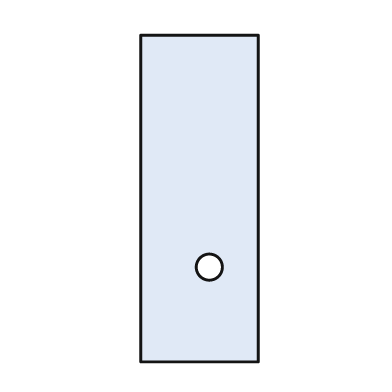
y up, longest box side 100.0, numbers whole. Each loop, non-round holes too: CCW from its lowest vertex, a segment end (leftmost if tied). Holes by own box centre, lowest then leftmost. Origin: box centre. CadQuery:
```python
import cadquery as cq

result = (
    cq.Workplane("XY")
    .moveTo(-18.0, -50.0)
    .lineTo(18.0, -50.0)
    .lineTo(18.0, 50.0)
    .lineTo(-18.0, 50.0)
    .close()
    .moveTo(3.0, -21.0)
    .circle(4.0)
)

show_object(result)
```